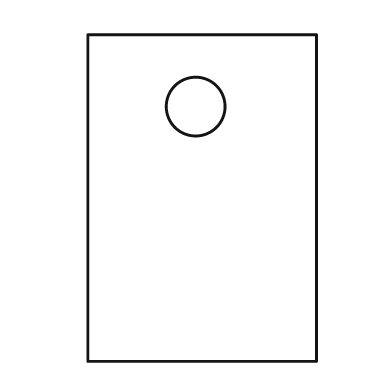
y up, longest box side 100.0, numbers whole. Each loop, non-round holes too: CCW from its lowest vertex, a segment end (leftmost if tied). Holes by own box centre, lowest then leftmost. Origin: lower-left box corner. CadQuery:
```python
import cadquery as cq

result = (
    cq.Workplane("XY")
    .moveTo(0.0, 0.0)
    .lineTo(70.0, 0.0)
    .lineTo(70.0, 100.0)
    .lineTo(0.0, 100.0)
    .close()
    .moveTo(33.0, 78.0)
    .circle(9.0)
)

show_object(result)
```